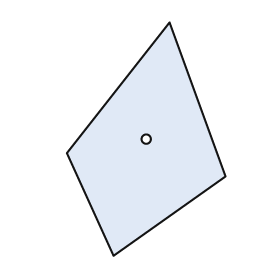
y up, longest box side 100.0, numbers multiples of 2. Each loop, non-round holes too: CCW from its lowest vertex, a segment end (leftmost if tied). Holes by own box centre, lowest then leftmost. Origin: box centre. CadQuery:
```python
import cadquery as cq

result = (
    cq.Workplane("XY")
    .moveTo(-14.0, -50.0)
    .lineTo(34.0, -16.0)
    .lineTo(10.0, 50.0)
    .lineTo(-34.0, -6.0)
    .close()
    .moveTo(0.0, 0.0)
    .circle(2.0)
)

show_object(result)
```